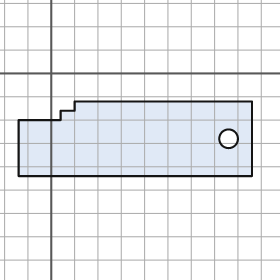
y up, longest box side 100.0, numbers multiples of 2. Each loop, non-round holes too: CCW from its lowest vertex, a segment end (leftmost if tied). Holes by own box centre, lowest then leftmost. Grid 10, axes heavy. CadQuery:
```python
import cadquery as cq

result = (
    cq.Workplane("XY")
    .moveTo(-14.0, -44.0)
    .lineTo(86.0, -44.0)
    .lineTo(86.0, -12.0)
    .lineTo(10.0, -12.0)
    .lineTo(10.0, -16.0)
    .lineTo(4.0, -16.0)
    .lineTo(4.0, -20.0)
    .lineTo(-14.0, -20.0)
    .close()
    .moveTo(76.0, -28.0)
    .circle(4.0)
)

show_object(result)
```